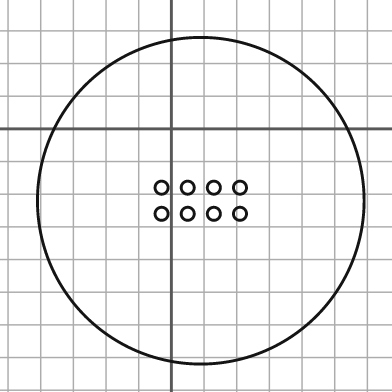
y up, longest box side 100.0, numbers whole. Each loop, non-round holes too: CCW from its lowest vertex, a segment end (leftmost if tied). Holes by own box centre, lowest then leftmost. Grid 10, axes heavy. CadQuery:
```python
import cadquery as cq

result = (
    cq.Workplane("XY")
    .moveTo(9.0, -22.0)
    .circle(50.0)
    .moveTo(-3.0, -26.0)
    .circle(2.0)
    .moveTo(5.0, -26.0)
    .circle(2.0)
    .moveTo(13.0, -26.0)
    .circle(2.0)
    .moveTo(21.0, -26.0)
    .circle(2.0)
    .moveTo(-3.0, -18.0)
    .circle(2.0)
    .moveTo(5.0, -18.0)
    .circle(2.0)
    .moveTo(13.0, -18.0)
    .circle(2.0)
    .moveTo(21.0, -18.0)
    .circle(2.0)
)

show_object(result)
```